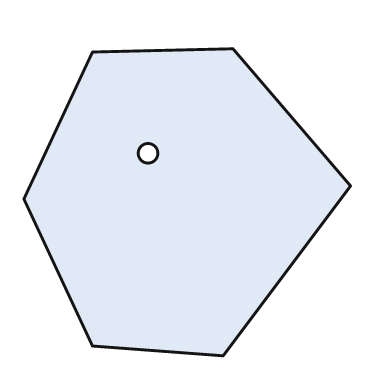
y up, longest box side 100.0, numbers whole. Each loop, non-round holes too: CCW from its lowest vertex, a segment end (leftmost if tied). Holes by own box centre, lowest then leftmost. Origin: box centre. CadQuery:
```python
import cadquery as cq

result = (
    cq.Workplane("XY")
    .moveTo(11.0, -47.0)
    .lineTo(50.0, 5.0)
    .lineTo(14.0, 47.0)
    .lineTo(-29.0, 46.0)
    .lineTo(-50.0, 1.0)
    .lineTo(-29.0, -44.0)
    .close()
    .moveTo(-12.0, 15.0)
    .circle(3.0)
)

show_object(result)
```